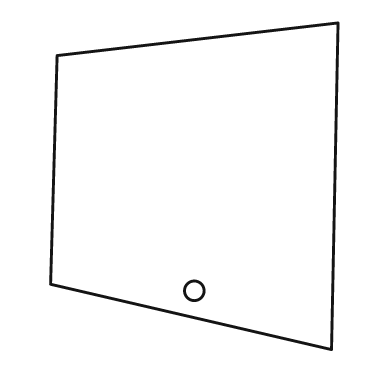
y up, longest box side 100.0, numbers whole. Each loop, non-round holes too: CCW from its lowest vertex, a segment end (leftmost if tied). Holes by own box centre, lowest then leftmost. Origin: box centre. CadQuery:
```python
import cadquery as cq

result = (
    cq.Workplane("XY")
    .moveTo(42.0, -50.0)
    .lineTo(44.0, 50.0)
    .lineTo(-42.0, 40.0)
    .lineTo(-44.0, -30.0)
    .close()
    .moveTo(0.0, -32.0)
    .circle(3.0)
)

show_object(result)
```